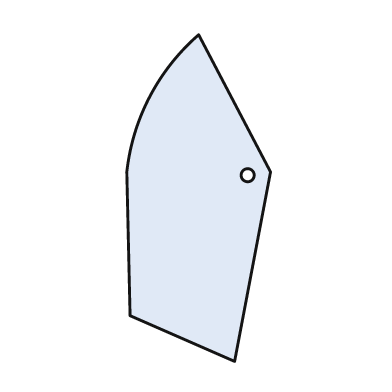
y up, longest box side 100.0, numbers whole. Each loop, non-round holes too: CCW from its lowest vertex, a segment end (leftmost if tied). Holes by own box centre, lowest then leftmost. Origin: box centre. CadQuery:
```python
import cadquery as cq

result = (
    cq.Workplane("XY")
    .moveTo(11.0, -50.0)
    .lineTo(22.0, 8.0)
    .lineTo(0.0, 50.0)
    .threePointArc((-15.0, 31.0), (-22.0, 8.0))
    .lineTo(-21.0, -36.0)
    .close()
    .moveTo(15.0, 7.0)
    .circle(2.0)
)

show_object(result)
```